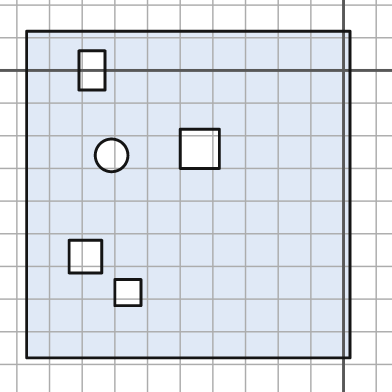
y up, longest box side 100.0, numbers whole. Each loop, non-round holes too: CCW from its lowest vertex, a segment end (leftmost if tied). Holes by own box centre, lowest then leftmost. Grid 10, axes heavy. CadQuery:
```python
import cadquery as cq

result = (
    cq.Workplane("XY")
    .moveTo(-97.0, -88.0)
    .lineTo(2.0, -88.0)
    .lineTo(2.0, 12.0)
    .lineTo(-97.0, 12.0)
    .close()
    .moveTo(-70.0, -72.0)
    .lineTo(-62.0, -72.0)
    .lineTo(-62.0, -64.0)
    .lineTo(-70.0, -64.0)
    .close()
    .moveTo(-84.0, -62.0)
    .lineTo(-74.0, -62.0)
    .lineTo(-74.0, -52.0)
    .lineTo(-84.0, -52.0)
    .close()
    .moveTo(-71.0, -26.0)
    .circle(5.0)
    .moveTo(-50.0, -30.0)
    .lineTo(-38.0, -30.0)
    .lineTo(-38.0, -18.0)
    .lineTo(-50.0, -18.0)
    .close()
    .moveTo(-81.0, -6.0)
    .lineTo(-73.0, -6.0)
    .lineTo(-73.0, 6.0)
    .lineTo(-81.0, 6.0)
    .close()
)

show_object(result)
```